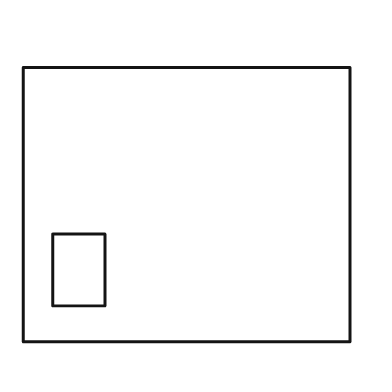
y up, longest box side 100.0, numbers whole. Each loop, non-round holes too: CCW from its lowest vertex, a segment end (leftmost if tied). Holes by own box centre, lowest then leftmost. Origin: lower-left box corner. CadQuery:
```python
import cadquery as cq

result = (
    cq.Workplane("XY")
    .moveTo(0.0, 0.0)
    .lineTo(100.0, 0.0)
    .lineTo(100.0, 84.0)
    .lineTo(0.0, 84.0)
    .close()
    .moveTo(9.0, 11.0)
    .lineTo(25.0, 11.0)
    .lineTo(25.0, 33.0)
    .lineTo(9.0, 33.0)
    .close()
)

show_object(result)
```